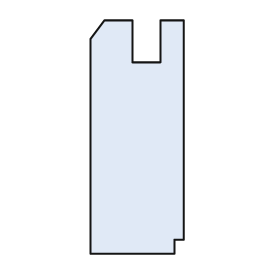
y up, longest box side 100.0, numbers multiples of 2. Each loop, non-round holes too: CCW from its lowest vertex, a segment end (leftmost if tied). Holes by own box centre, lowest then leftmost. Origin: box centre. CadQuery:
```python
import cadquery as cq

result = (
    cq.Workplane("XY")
    .moveTo(-20.0, -50.0)
    .lineTo(16.0, -50.0)
    .lineTo(16.0, -44.0)
    .lineTo(20.0, -44.0)
    .lineTo(20.0, 50.0)
    .lineTo(10.0, 50.0)
    .lineTo(10.0, 32.0)
    .lineTo(-2.0, 32.0)
    .lineTo(-2.0, 50.0)
    .lineTo(-14.0, 50.0)
    .lineTo(-20.0, 42.0)
    .close()
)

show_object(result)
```